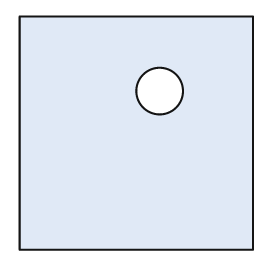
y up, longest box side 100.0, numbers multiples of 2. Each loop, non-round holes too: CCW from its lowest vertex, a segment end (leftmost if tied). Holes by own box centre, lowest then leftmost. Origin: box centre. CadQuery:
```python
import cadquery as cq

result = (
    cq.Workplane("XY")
    .moveTo(-50.0, -50.0)
    .lineTo(50.0, -50.0)
    .lineTo(50.0, 50.0)
    .lineTo(-50.0, 50.0)
    .close()
    .moveTo(10.0, 18.0)
    .circle(10.0)
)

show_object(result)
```